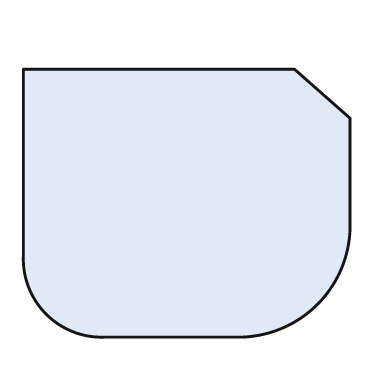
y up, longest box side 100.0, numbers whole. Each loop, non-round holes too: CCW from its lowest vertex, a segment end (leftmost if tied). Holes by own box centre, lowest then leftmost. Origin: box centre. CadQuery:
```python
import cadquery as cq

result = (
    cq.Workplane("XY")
    .moveTo(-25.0, -41.0)
    .lineTo(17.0, -41.0)
    .threePointArc((40.0, -31.0), (50.0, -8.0))
    .lineTo(50.0, 26.0)
    .lineTo(33.0, 41.0)
    .lineTo(-50.0, 41.0)
    .lineTo(-50.0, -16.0)
    .threePointArc((-43.0, -34.0), (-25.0, -41.0))
    .close()
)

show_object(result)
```